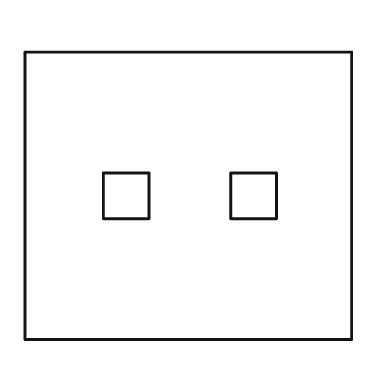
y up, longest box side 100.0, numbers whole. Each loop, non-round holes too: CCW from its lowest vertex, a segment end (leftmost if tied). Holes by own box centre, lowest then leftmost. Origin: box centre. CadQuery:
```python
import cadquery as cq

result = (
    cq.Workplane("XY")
    .moveTo(-50.0, -44.0)
    .lineTo(50.0, -44.0)
    .lineTo(50.0, 44.0)
    .lineTo(-50.0, 44.0)
    .close()
    .moveTo(-26.0, -7.0)
    .lineTo(-12.0, -7.0)
    .lineTo(-12.0, 7.0)
    .lineTo(-26.0, 7.0)
    .close()
    .moveTo(13.0, -7.0)
    .lineTo(27.0, -7.0)
    .lineTo(27.0, 7.0)
    .lineTo(13.0, 7.0)
    .close()
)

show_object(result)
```